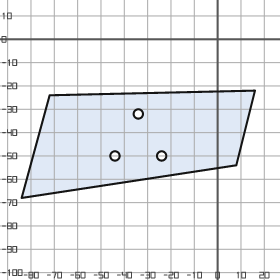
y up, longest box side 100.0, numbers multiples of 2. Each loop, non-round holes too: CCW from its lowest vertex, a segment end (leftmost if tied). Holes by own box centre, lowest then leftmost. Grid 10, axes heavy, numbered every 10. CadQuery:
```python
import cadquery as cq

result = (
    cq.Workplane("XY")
    .moveTo(-84.0, -68.0)
    .lineTo(8.0, -54.0)
    .lineTo(16.0, -22.0)
    .lineTo(-72.0, -24.0)
    .close()
    .moveTo(-44.0, -50.0)
    .circle(2.0)
    .moveTo(-24.0, -50.0)
    .circle(2.0)
    .moveTo(-34.0, -32.0)
    .circle(2.0)
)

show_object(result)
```